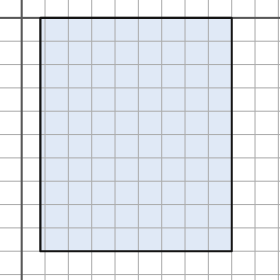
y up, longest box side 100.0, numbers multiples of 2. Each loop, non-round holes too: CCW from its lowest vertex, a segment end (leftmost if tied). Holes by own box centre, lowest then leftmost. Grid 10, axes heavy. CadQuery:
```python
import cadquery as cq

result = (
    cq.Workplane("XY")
    .moveTo(8.0, -100.0)
    .lineTo(90.0, -100.0)
    .lineTo(90.0, 0.0)
    .lineTo(8.0, 0.0)
    .close()
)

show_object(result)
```